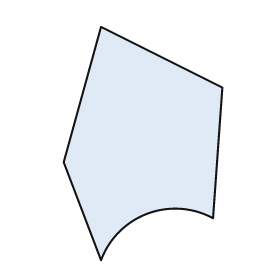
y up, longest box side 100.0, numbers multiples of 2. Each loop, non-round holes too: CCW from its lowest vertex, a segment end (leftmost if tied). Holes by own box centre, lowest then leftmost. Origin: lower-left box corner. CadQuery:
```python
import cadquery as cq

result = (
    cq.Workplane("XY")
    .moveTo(16.0, 0.0)
    .threePointArc((36.0, 20.0), (64.0, 18.0))
    .lineTo(68.0, 74.0)
    .lineTo(16.0, 100.0)
    .lineTo(0.0, 42.0)
    .close()
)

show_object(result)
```